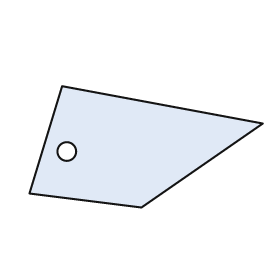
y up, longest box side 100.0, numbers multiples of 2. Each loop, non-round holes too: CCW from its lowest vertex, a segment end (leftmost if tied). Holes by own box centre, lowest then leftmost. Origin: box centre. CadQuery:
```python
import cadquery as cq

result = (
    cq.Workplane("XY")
    .moveTo(-2.0, -26.0)
    .lineTo(50.0, 10.0)
    .lineTo(-36.0, 26.0)
    .lineTo(-50.0, -20.0)
    .close()
    .moveTo(-34.0, -2.0)
    .circle(4.0)
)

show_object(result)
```